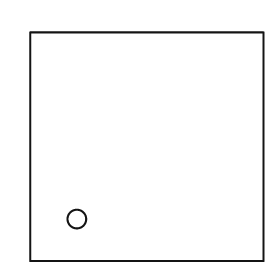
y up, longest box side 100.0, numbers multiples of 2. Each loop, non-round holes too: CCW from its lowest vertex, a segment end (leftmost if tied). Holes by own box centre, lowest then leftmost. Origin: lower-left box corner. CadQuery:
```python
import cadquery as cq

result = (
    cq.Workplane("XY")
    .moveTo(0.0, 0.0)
    .lineTo(100.0, 0.0)
    .lineTo(100.0, 98.0)
    .lineTo(0.0, 98.0)
    .close()
    .moveTo(20.0, 18.0)
    .circle(4.0)
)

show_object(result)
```